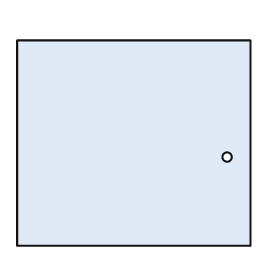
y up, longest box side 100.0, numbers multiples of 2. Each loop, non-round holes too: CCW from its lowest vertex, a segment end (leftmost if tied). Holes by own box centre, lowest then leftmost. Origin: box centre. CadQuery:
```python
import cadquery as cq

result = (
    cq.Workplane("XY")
    .moveTo(-50.0, -44.0)
    .lineTo(50.0, -44.0)
    .lineTo(50.0, 44.0)
    .lineTo(-50.0, 44.0)
    .close()
    .moveTo(40.0, -6.0)
    .circle(2.0)
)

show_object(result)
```